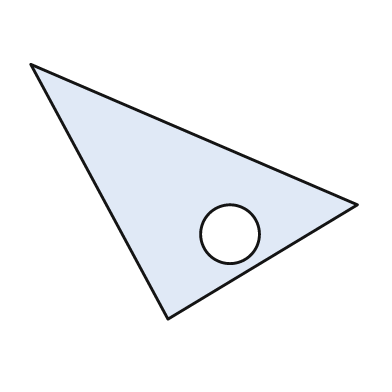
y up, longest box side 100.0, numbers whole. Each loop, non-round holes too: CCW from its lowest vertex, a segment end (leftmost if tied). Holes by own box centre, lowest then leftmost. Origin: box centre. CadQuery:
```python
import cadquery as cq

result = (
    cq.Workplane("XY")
    .moveTo(-8.0, -39.0)
    .lineTo(50.0, -4.0)
    .lineTo(-50.0, 39.0)
    .close()
    .moveTo(11.0, -13.0)
    .circle(9.0)
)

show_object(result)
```